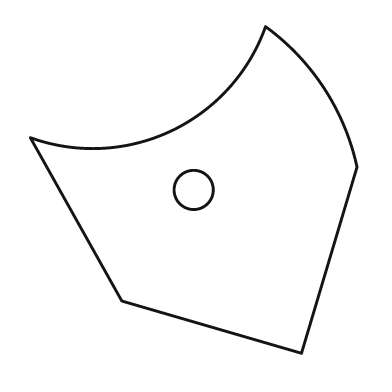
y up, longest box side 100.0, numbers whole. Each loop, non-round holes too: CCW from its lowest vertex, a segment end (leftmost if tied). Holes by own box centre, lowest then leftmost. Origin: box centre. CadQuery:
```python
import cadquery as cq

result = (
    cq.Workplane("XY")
    .moveTo(33.0, -50.0)
    .lineTo(50.0, 7.0)
    .threePointArc((40.0, 31.0), (22.0, 50.0))
    .threePointArc((-7.0, 18.0), (-50.0, 16.0))
    .lineTo(-22.0, -34.0)
    .close()
    .moveTo(0.0, 0.0)
    .circle(6.0)
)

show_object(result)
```